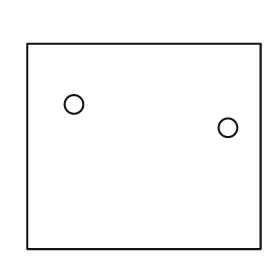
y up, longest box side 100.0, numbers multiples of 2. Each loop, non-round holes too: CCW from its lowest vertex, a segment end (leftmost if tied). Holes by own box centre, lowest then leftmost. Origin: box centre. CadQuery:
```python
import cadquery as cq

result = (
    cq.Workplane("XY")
    .moveTo(-50.0, -44.0)
    .lineTo(50.0, -44.0)
    .lineTo(50.0, 44.0)
    .lineTo(-50.0, 44.0)
    .close()
    .moveTo(36.0, 8.0)
    .circle(4.0)
    .moveTo(-30.0, 18.0)
    .circle(4.0)
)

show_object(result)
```